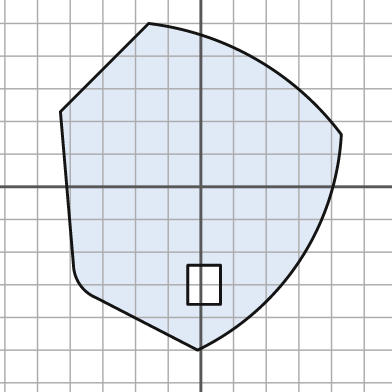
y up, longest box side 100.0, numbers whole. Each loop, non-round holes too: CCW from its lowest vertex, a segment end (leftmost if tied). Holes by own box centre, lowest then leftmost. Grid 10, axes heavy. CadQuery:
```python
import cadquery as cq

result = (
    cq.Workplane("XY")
    .moveTo(-1.0, -50.0)
    .threePointArc((30.0, -23.0), (43.0, 16.0))
    .threePointArc((17.0, 39.0), (-16.0, 50.0))
    .lineTo(-43.0, 23.0)
    .lineTo(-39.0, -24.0)
    .threePointArc((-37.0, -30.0), (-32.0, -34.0))
    .close()
    .moveTo(-4.0, -36.0)
    .lineTo(6.0, -36.0)
    .lineTo(6.0, -24.0)
    .lineTo(-4.0, -24.0)
    .close()
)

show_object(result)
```